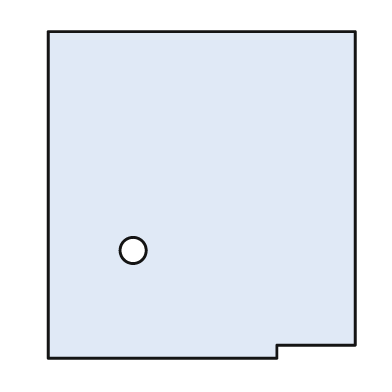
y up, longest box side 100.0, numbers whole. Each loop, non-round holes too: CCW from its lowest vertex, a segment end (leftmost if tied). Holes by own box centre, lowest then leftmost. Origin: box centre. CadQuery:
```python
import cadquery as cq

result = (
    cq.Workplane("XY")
    .moveTo(-47.0, -50.0)
    .lineTo(23.0, -50.0)
    .lineTo(23.0, -46.0)
    .lineTo(47.0, -46.0)
    .lineTo(47.0, 50.0)
    .lineTo(-47.0, 50.0)
    .close()
    .moveTo(-21.0, -17.0)
    .circle(4.0)
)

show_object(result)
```